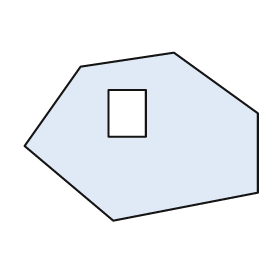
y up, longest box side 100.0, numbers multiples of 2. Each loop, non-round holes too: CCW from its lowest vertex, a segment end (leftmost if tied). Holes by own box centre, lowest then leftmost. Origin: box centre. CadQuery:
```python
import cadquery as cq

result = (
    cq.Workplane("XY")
    .moveTo(-12.0, -36.0)
    .lineTo(50.0, -24.0)
    .lineTo(50.0, 10.0)
    .lineTo(14.0, 36.0)
    .lineTo(-26.0, 30.0)
    .lineTo(-50.0, -4.0)
    .close()
    .moveTo(-14.0, 0.0)
    .lineTo(2.0, 0.0)
    .lineTo(2.0, 20.0)
    .lineTo(-14.0, 20.0)
    .close()
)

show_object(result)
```